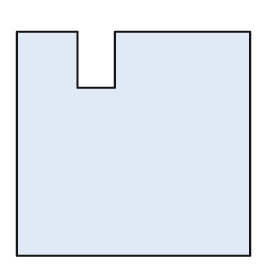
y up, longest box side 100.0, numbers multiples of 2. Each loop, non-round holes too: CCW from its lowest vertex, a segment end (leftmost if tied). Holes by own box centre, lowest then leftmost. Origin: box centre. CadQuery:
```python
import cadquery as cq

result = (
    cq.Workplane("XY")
    .moveTo(-50.0, -48.0)
    .lineTo(50.0, -48.0)
    .lineTo(50.0, 48.0)
    .lineTo(-8.0, 48.0)
    .lineTo(-8.0, 24.0)
    .lineTo(-24.0, 24.0)
    .lineTo(-24.0, 48.0)
    .lineTo(-50.0, 48.0)
    .close()
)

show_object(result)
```